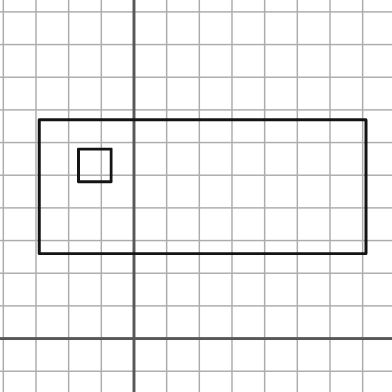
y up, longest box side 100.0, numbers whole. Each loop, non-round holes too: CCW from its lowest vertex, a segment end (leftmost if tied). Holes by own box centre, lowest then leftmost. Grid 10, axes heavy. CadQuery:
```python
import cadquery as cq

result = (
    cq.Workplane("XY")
    .moveTo(-29.0, 26.0)
    .lineTo(71.0, 26.0)
    .lineTo(71.0, 67.0)
    .lineTo(-29.0, 67.0)
    .close()
    .moveTo(-17.0, 48.0)
    .lineTo(-7.0, 48.0)
    .lineTo(-7.0, 58.0)
    .lineTo(-17.0, 58.0)
    .close()
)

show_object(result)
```